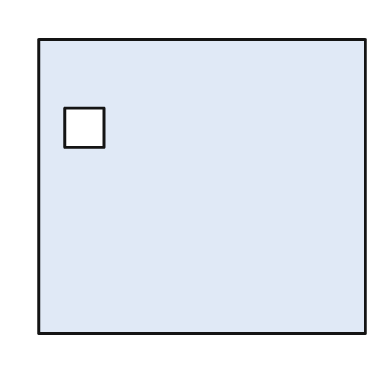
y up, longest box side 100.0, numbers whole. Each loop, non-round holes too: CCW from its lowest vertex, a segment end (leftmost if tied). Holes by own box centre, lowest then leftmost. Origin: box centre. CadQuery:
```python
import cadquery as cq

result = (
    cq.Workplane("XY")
    .moveTo(-50.0, -45.0)
    .lineTo(50.0, -45.0)
    .lineTo(50.0, 45.0)
    .lineTo(-50.0, 45.0)
    .close()
    .moveTo(-42.0, 12.0)
    .lineTo(-30.0, 12.0)
    .lineTo(-30.0, 24.0)
    .lineTo(-42.0, 24.0)
    .close()
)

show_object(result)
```